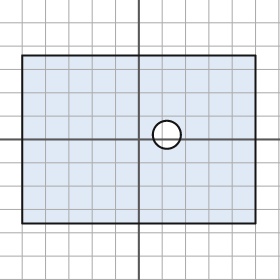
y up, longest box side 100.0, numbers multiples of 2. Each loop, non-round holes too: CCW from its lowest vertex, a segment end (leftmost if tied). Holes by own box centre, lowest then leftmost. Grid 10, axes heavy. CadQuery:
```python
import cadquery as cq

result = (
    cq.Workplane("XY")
    .moveTo(-50.0, -36.0)
    .lineTo(50.0, -36.0)
    .lineTo(50.0, 36.0)
    .lineTo(-50.0, 36.0)
    .close()
    .moveTo(12.0, 2.0)
    .circle(6.0)
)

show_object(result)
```